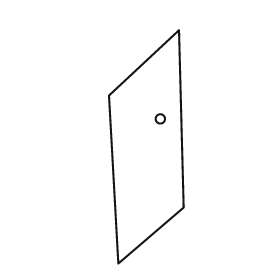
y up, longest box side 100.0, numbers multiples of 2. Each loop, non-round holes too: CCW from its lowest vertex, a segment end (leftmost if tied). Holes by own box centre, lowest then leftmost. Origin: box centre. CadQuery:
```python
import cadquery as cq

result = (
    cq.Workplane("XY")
    .moveTo(-12.0, -50.0)
    .lineTo(16.0, -26.0)
    .lineTo(14.0, 50.0)
    .lineTo(-16.0, 22.0)
    .close()
    .moveTo(6.0, 12.0)
    .circle(2.0)
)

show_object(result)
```